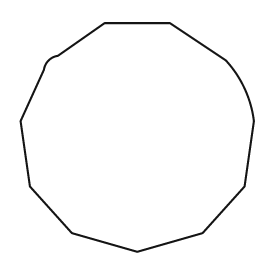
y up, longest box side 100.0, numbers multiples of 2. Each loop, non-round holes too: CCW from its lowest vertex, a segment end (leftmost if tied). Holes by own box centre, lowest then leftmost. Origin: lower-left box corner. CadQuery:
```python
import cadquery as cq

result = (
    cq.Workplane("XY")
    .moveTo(50.0, 0.0)
    .lineTo(78.0, 8.0)
    .lineTo(96.0, 28.0)
    .lineTo(100.0, 56.0)
    .threePointArc((96.0, 70.0), (88.0, 82.0))
    .lineTo(64.0, 98.0)
    .lineTo(36.0, 98.0)
    .lineTo(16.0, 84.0)
    .threePointArc((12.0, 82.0), (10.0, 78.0))
    .lineTo(0.0, 56.0)
    .lineTo(4.0, 28.0)
    .lineTo(22.0, 8.0)
    .close()
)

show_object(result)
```